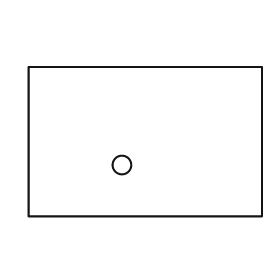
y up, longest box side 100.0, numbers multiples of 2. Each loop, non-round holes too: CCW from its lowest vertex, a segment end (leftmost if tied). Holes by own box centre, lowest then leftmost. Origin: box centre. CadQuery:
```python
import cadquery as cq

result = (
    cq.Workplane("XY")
    .moveTo(-50.0, -32.0)
    .lineTo(50.0, -32.0)
    .lineTo(50.0, 32.0)
    .lineTo(-50.0, 32.0)
    .close()
    .moveTo(-10.0, -10.0)
    .circle(4.0)
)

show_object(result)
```